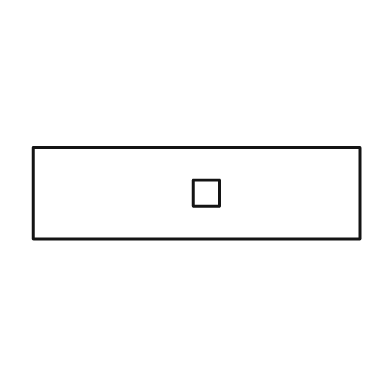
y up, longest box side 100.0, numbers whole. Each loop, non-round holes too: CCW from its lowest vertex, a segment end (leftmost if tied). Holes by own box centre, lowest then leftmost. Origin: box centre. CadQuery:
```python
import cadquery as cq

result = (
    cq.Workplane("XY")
    .moveTo(-50.0, -14.0)
    .lineTo(50.0, -14.0)
    .lineTo(50.0, 14.0)
    .lineTo(-50.0, 14.0)
    .close()
    .moveTo(-1.0, -4.0)
    .lineTo(7.0, -4.0)
    .lineTo(7.0, 4.0)
    .lineTo(-1.0, 4.0)
    .close()
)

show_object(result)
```